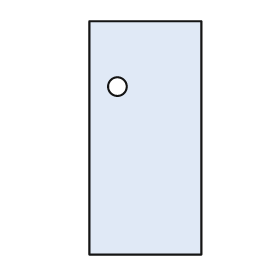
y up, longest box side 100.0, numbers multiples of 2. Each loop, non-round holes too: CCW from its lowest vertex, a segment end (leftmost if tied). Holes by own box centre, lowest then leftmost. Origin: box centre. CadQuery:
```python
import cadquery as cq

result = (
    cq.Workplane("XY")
    .moveTo(-24.0, -50.0)
    .lineTo(24.0, -50.0)
    .lineTo(24.0, 50.0)
    .lineTo(-24.0, 50.0)
    .close()
    .moveTo(-12.0, 22.0)
    .circle(4.0)
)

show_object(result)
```